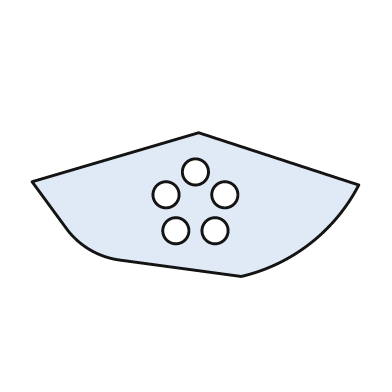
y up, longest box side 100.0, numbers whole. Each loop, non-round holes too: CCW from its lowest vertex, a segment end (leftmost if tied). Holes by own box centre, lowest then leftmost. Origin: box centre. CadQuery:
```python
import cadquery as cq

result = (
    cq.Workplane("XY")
    .moveTo(14.0, -22.0)
    .threePointArc((35.0, -12.0), (50.0, 6.0))
    .lineTo(1.0, 22.0)
    .lineTo(-50.0, 7.0)
    .lineTo(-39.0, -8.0)
    .threePointArc((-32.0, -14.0), (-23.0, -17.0))
    .close()
    .moveTo(-6.0, -8.0)
    .circle(4.0)
    .moveTo(6.0, -8.0)
    .circle(4.0)
    .moveTo(-9.0, 3.0)
    .circle(4.0)
    .moveTo(9.0, 3.0)
    .circle(4.0)
    .moveTo(0.0, 10.0)
    .circle(4.0)
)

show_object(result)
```